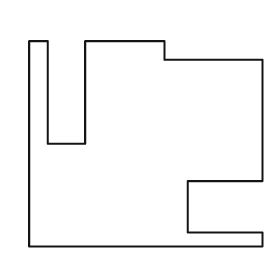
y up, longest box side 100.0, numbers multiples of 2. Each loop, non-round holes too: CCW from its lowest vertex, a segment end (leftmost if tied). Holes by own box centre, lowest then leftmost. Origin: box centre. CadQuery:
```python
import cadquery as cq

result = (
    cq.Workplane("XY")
    .moveTo(-50.0, -44.0)
    .lineTo(50.0, -44.0)
    .lineTo(50.0, -38.0)
    .lineTo(18.0, -38.0)
    .lineTo(18.0, -16.0)
    .lineTo(50.0, -16.0)
    .lineTo(50.0, 36.0)
    .lineTo(8.0, 36.0)
    .lineTo(8.0, 44.0)
    .lineTo(-26.0, 44.0)
    .lineTo(-26.0, 0.0)
    .lineTo(-42.0, 0.0)
    .lineTo(-42.0, 44.0)
    .lineTo(-50.0, 44.0)
    .close()
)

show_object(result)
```